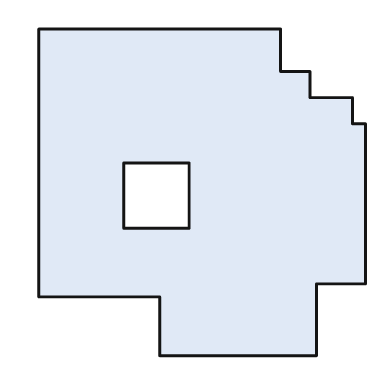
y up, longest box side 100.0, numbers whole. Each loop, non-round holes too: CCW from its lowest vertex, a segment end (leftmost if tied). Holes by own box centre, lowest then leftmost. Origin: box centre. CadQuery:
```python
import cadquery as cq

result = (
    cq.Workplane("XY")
    .moveTo(-13.0, -50.0)
    .lineTo(35.0, -50.0)
    .lineTo(35.0, -28.0)
    .lineTo(50.0, -28.0)
    .lineTo(50.0, 21.0)
    .lineTo(46.0, 21.0)
    .lineTo(46.0, 29.0)
    .lineTo(33.0, 29.0)
    .lineTo(33.0, 37.0)
    .lineTo(24.0, 37.0)
    .lineTo(24.0, 50.0)
    .lineTo(-50.0, 50.0)
    .lineTo(-50.0, -32.0)
    .lineTo(-13.0, -32.0)
    .close()
    .moveTo(-24.0, -11.0)
    .lineTo(-4.0, -11.0)
    .lineTo(-4.0, 9.0)
    .lineTo(-24.0, 9.0)
    .close()
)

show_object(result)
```